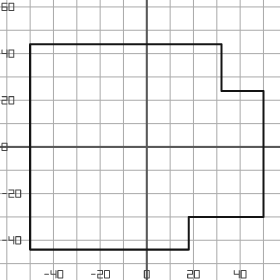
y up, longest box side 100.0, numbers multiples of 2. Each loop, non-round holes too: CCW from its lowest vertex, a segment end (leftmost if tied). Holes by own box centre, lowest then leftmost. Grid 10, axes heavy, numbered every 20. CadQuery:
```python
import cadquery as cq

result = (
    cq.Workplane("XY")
    .moveTo(-50.0, -44.0)
    .lineTo(18.0, -44.0)
    .lineTo(18.0, -30.0)
    .lineTo(50.0, -30.0)
    .lineTo(50.0, 24.0)
    .lineTo(32.0, 24.0)
    .lineTo(32.0, 44.0)
    .lineTo(-50.0, 44.0)
    .close()
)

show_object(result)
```